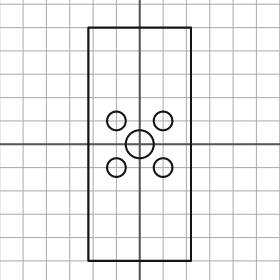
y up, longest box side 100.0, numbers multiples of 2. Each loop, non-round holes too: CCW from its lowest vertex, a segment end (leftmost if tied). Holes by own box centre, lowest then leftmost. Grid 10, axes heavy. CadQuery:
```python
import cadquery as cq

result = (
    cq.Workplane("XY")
    .moveTo(-22.0, -50.0)
    .lineTo(22.0, -50.0)
    .lineTo(22.0, 50.0)
    .lineTo(-22.0, 50.0)
    .close()
    .moveTo(-10.0, -10.0)
    .circle(4.0)
    .moveTo(10.0, -10.0)
    .circle(4.0)
    .moveTo(0.0, 0.0)
    .circle(6.0)
    .moveTo(-10.0, 10.0)
    .circle(4.0)
    .moveTo(10.0, 10.0)
    .circle(4.0)
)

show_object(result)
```